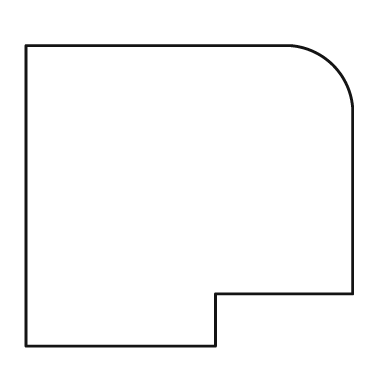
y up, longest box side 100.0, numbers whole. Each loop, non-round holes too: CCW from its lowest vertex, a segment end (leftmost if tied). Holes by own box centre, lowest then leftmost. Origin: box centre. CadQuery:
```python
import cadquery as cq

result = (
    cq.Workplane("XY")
    .moveTo(-50.0, -46.0)
    .lineTo(8.0, -46.0)
    .lineTo(8.0, -30.0)
    .lineTo(50.0, -30.0)
    .lineTo(50.0, 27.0)
    .threePointArc((44.0, 40.0), (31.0, 46.0))
    .lineTo(-50.0, 46.0)
    .close()
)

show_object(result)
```